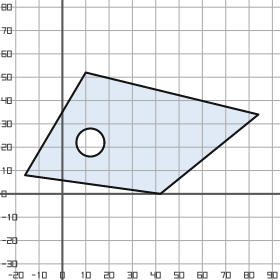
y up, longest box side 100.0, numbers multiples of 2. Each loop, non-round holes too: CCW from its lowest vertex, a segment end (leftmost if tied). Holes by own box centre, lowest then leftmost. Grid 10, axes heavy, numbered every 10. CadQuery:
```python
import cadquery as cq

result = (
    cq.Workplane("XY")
    .moveTo(42.0, 0.0)
    .lineTo(84.0, 34.0)
    .lineTo(10.0, 52.0)
    .lineTo(-16.0, 8.0)
    .close()
    .moveTo(12.0, 22.0)
    .circle(6.0)
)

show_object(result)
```